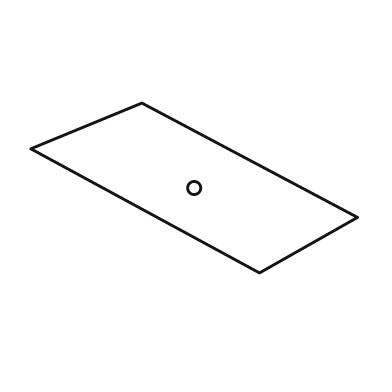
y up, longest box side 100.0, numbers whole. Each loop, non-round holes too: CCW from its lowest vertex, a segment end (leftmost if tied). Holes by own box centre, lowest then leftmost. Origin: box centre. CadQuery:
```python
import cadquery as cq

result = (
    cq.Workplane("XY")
    .moveTo(20.0, -26.0)
    .lineTo(50.0, -9.0)
    .lineTo(-16.0, 26.0)
    .lineTo(-50.0, 12.0)
    .close()
    .moveTo(0.0, 0.0)
    .circle(2.0)
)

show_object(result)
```